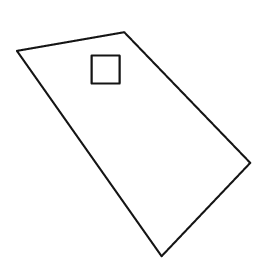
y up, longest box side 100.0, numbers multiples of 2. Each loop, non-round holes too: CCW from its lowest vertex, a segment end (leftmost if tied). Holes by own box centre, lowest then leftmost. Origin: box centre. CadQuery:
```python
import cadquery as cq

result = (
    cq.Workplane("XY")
    .moveTo(12.0, -48.0)
    .lineTo(50.0, -8.0)
    .lineTo(-4.0, 48.0)
    .lineTo(-50.0, 40.0)
    .close()
    .moveTo(-18.0, 26.0)
    .lineTo(-6.0, 26.0)
    .lineTo(-6.0, 38.0)
    .lineTo(-18.0, 38.0)
    .close()
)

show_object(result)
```